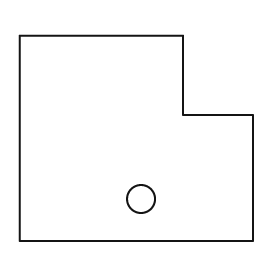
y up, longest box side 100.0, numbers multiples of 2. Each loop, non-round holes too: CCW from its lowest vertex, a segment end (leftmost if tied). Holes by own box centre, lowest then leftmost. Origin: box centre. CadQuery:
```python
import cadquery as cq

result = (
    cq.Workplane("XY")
    .moveTo(-50.0, -44.0)
    .lineTo(50.0, -44.0)
    .lineTo(50.0, 10.0)
    .lineTo(20.0, 10.0)
    .lineTo(20.0, 44.0)
    .lineTo(-50.0, 44.0)
    .close()
    .moveTo(2.0, -26.0)
    .circle(6.0)
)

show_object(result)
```